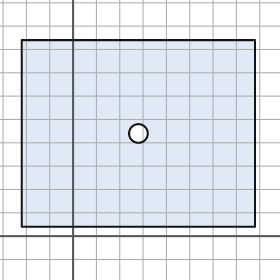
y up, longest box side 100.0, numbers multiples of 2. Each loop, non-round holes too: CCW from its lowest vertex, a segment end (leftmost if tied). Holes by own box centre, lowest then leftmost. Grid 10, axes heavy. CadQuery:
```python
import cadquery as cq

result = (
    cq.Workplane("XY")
    .moveTo(-22.0, 4.0)
    .lineTo(78.0, 4.0)
    .lineTo(78.0, 84.0)
    .lineTo(-22.0, 84.0)
    .close()
    .moveTo(28.0, 44.0)
    .circle(4.0)
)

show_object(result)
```